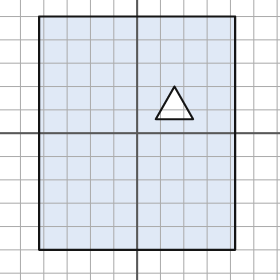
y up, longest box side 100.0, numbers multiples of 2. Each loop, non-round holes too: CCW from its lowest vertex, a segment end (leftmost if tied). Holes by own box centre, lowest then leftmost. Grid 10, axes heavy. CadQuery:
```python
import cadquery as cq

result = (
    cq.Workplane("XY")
    .moveTo(-42.0, -50.0)
    .lineTo(42.0, -50.0)
    .lineTo(42.0, 50.0)
    .lineTo(-42.0, 50.0)
    .close()
    .moveTo(8.0, 6.0)
    .lineTo(24.0, 6.0)
    .lineTo(16.0, 20.0)
    .close()
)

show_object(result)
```